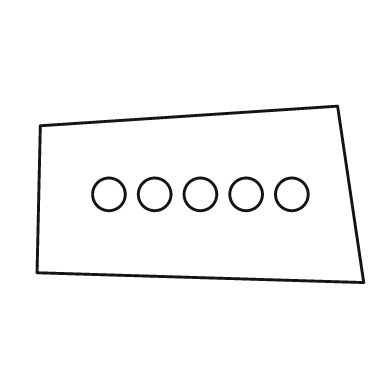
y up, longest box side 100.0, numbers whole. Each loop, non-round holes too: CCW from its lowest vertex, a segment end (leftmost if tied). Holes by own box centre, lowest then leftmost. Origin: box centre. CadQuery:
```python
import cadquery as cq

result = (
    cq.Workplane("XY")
    .moveTo(50.0, -27.0)
    .lineTo(42.0, 27.0)
    .lineTo(-49.0, 21.0)
    .lineTo(-50.0, -24.0)
    .close()
    .moveTo(-28.0, 0.0)
    .circle(5.0)
    .moveTo(-14.0, 0.0)
    .circle(5.0)
    .moveTo(0.0, 0.0)
    .circle(5.0)
    .moveTo(14.0, 0.0)
    .circle(5.0)
    .moveTo(28.0, 0.0)
    .circle(5.0)
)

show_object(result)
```